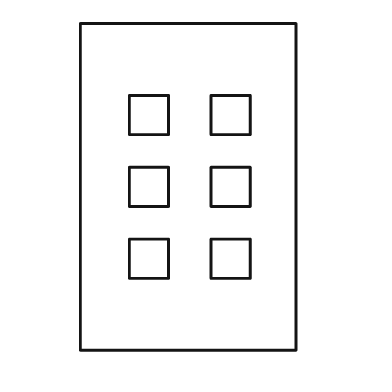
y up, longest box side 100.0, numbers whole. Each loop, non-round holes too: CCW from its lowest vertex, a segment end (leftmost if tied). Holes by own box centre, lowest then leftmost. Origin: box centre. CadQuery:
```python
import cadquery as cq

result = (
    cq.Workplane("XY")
    .moveTo(-33.0, -50.0)
    .lineTo(33.0, -50.0)
    .lineTo(33.0, 50.0)
    .lineTo(-33.0, 50.0)
    .close()
    .moveTo(-18.0, -28.0)
    .lineTo(-6.0, -28.0)
    .lineTo(-6.0, -16.0)
    .lineTo(-18.0, -16.0)
    .close()
    .moveTo(7.0, -28.0)
    .lineTo(19.0, -28.0)
    .lineTo(19.0, -16.0)
    .lineTo(7.0, -16.0)
    .close()
    .moveTo(-18.0, -6.0)
    .lineTo(-6.0, -6.0)
    .lineTo(-6.0, 6.0)
    .lineTo(-18.0, 6.0)
    .close()
    .moveTo(7.0, -6.0)
    .lineTo(19.0, -6.0)
    .lineTo(19.0, 6.0)
    .lineTo(7.0, 6.0)
    .close()
    .moveTo(-18.0, 16.0)
    .lineTo(-6.0, 16.0)
    .lineTo(-6.0, 28.0)
    .lineTo(-18.0, 28.0)
    .close()
    .moveTo(7.0, 16.0)
    .lineTo(19.0, 16.0)
    .lineTo(19.0, 28.0)
    .lineTo(7.0, 28.0)
    .close()
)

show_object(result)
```